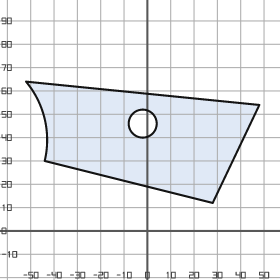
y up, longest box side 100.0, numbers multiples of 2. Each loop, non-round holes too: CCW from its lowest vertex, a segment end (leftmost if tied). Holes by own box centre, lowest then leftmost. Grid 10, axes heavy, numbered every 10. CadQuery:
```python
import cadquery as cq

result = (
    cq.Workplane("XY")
    .moveTo(28.0, 12.0)
    .lineTo(48.0, 54.0)
    .lineTo(-52.0, 64.0)
    .threePointArc((-44.0, 48.0), (-44.0, 30.0))
    .close()
    .moveTo(-2.0, 46.0)
    .circle(6.0)
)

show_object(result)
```